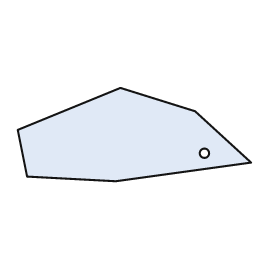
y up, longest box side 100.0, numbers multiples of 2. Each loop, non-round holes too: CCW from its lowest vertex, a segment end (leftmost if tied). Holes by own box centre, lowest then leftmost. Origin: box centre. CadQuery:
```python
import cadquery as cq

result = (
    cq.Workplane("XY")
    .moveTo(-8.0, -20.0)
    .lineTo(50.0, -12.0)
    .lineTo(26.0, 10.0)
    .lineTo(-6.0, 20.0)
    .lineTo(-50.0, 2.0)
    .lineTo(-46.0, -18.0)
    .close()
    .moveTo(30.0, -8.0)
    .circle(2.0)
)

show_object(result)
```